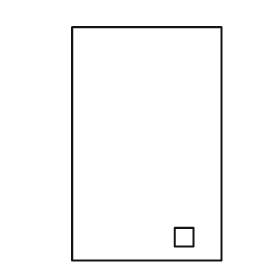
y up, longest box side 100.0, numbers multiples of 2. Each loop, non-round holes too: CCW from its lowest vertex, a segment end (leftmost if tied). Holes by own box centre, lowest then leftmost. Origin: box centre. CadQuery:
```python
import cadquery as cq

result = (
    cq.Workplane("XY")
    .moveTo(-32.0, -50.0)
    .lineTo(32.0, -50.0)
    .lineTo(32.0, 50.0)
    .lineTo(-32.0, 50.0)
    .close()
    .moveTo(12.0, -44.0)
    .lineTo(20.0, -44.0)
    .lineTo(20.0, -36.0)
    .lineTo(12.0, -36.0)
    .close()
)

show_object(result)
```